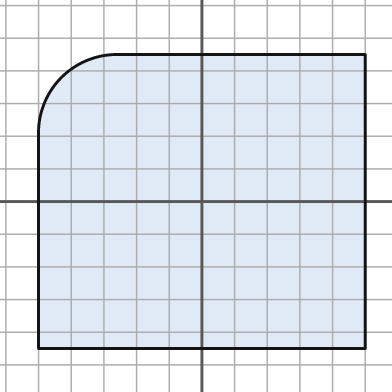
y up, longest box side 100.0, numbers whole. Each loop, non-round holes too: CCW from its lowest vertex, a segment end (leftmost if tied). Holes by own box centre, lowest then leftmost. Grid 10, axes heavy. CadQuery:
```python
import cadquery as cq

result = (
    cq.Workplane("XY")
    .moveTo(-50.0, -45.0)
    .lineTo(50.0, -45.0)
    .lineTo(50.0, 45.0)
    .lineTo(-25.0, 45.0)
    .threePointArc((-43.0, 38.0), (-50.0, 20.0))
    .close()
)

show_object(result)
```